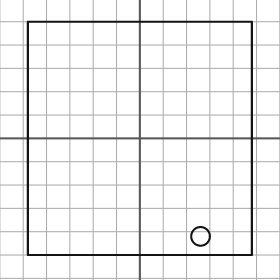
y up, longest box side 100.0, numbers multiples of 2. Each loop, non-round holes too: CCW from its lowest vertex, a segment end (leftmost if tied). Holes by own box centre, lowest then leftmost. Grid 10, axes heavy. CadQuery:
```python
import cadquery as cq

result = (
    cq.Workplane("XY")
    .moveTo(-48.0, -50.0)
    .lineTo(48.0, -50.0)
    .lineTo(48.0, 50.0)
    .lineTo(-48.0, 50.0)
    .close()
    .moveTo(26.0, -42.0)
    .circle(4.0)
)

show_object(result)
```